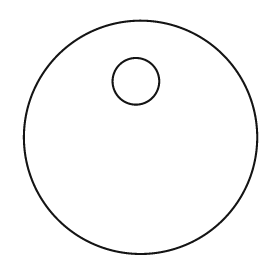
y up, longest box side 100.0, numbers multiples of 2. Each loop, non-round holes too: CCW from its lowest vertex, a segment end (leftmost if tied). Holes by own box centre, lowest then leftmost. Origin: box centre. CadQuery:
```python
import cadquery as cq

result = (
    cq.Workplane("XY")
    .moveTo(0.0, 0.0)
    .circle(50.0)
    .moveTo(-2.0, 24.0)
    .circle(10.0)
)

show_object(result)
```